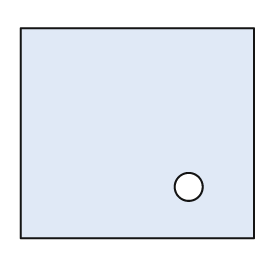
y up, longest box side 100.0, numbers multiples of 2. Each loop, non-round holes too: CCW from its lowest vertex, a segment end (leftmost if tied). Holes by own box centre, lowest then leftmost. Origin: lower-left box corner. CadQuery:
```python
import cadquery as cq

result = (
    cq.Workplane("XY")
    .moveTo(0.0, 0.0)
    .lineTo(100.0, 0.0)
    .lineTo(100.0, 90.0)
    .lineTo(0.0, 90.0)
    .close()
    .moveTo(72.0, 22.0)
    .circle(6.0)
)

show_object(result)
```